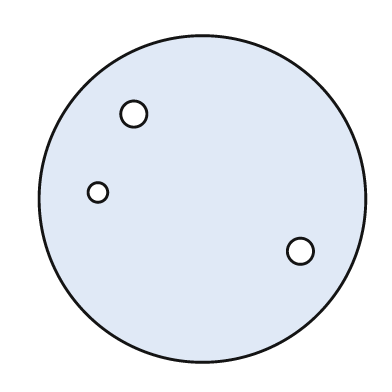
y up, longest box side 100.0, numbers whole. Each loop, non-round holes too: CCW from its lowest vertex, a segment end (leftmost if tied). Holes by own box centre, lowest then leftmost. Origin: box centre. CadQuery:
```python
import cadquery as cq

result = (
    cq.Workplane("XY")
    .moveTo(0.0, 0.0)
    .circle(50.0)
    .moveTo(30.0, -16.0)
    .circle(4.0)
    .moveTo(-32.0, 2.0)
    .circle(3.0)
    .moveTo(-21.0, 26.0)
    .circle(4.0)
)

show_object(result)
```